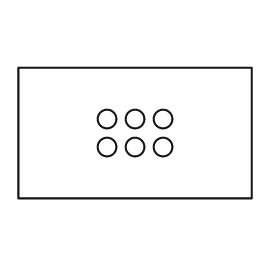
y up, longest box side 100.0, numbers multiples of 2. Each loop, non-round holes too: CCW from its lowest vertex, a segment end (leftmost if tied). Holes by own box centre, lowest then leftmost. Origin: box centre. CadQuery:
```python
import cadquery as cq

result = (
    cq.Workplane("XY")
    .moveTo(-50.0, -28.0)
    .lineTo(50.0, -28.0)
    .lineTo(50.0, 28.0)
    .lineTo(-50.0, 28.0)
    .close()
    .moveTo(-12.0, -6.0)
    .circle(4.0)
    .moveTo(0.0, -6.0)
    .circle(4.0)
    .moveTo(12.0, -6.0)
    .circle(4.0)
    .moveTo(-12.0, 6.0)
    .circle(4.0)
    .moveTo(0.0, 6.0)
    .circle(4.0)
    .moveTo(12.0, 6.0)
    .circle(4.0)
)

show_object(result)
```